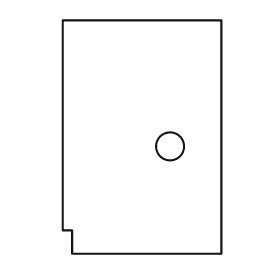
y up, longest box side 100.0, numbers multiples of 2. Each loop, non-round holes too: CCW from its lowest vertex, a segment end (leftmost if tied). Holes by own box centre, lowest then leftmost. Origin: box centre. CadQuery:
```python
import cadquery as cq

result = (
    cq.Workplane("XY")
    .moveTo(-30.0, -50.0)
    .lineTo(34.0, -50.0)
    .lineTo(34.0, 50.0)
    .lineTo(-34.0, 50.0)
    .lineTo(-34.0, -40.0)
    .lineTo(-30.0, -40.0)
    .close()
    .moveTo(12.0, -4.0)
    .circle(6.0)
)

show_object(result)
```